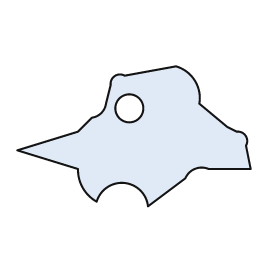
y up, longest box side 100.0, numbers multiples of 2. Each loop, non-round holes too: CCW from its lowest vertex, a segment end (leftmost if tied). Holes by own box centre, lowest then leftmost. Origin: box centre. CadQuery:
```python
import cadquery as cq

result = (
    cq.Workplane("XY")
    .moveTo(6.0, -30.0)
    .lineTo(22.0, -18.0)
    .threePointArc((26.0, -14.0), (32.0, -14.0))
    .lineTo(50.0, -14.0)
    .lineTo(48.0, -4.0)
    .threePointArc((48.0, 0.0), (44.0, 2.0))
    .lineTo(40.0, 4.0)
    .lineTo(28.0, 14.0)
    .threePointArc((26.0, 24.0), (18.0, 30.0))
    .lineTo(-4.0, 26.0)
    .threePointArc((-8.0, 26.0), (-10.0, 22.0))
    .lineTo(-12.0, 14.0)
    .threePointArc((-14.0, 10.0), (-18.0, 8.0))
    .lineTo(-24.0, 2.0)
    .lineTo(-50.0, -6.0)
    .lineTo(-24.0, -14.0)
    .threePointArc((-22.0, -22.0), (-16.0, -28.0))
    .threePointArc((-4.0, -20.0), (6.0, -30.0))
    .close()
    .moveTo(-2.0, 12.0)
    .circle(6.0)
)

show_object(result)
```